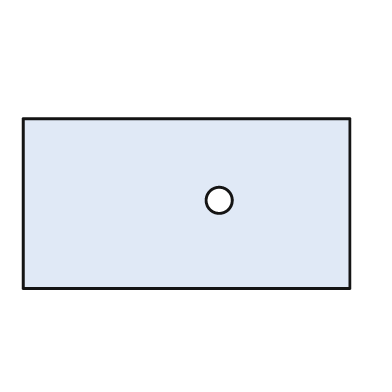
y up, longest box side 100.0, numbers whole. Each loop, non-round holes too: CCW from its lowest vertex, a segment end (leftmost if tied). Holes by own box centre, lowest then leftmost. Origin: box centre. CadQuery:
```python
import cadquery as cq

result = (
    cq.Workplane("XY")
    .moveTo(-50.0, -26.0)
    .lineTo(50.0, -26.0)
    .lineTo(50.0, 26.0)
    .lineTo(-50.0, 26.0)
    .close()
    .moveTo(10.0, 1.0)
    .circle(4.0)
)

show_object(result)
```